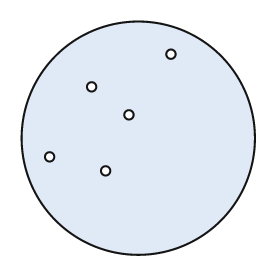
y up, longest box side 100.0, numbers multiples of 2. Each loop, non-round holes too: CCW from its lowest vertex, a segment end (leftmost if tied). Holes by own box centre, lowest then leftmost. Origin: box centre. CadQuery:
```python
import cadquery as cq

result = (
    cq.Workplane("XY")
    .moveTo(0.0, 0.0)
    .circle(50.0)
    .moveTo(-14.0, -14.0)
    .circle(2.0)
    .moveTo(-38.0, -8.0)
    .circle(2.0)
    .moveTo(-4.0, 10.0)
    .circle(2.0)
    .moveTo(-20.0, 22.0)
    .circle(2.0)
    .moveTo(14.0, 36.0)
    .circle(2.0)
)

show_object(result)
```